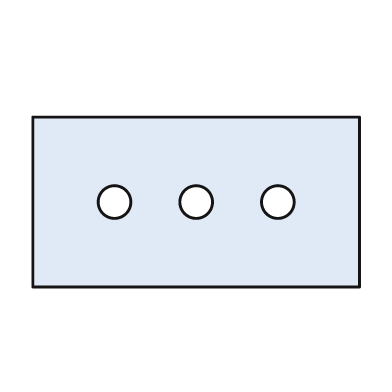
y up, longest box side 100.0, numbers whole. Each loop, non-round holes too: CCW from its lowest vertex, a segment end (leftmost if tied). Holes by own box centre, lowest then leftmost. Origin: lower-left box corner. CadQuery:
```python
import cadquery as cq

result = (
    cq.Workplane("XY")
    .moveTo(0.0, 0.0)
    .lineTo(100.0, 0.0)
    .lineTo(100.0, 52.0)
    .lineTo(0.0, 52.0)
    .close()
    .moveTo(25.0, 26.0)
    .circle(5.0)
    .moveTo(50.0, 26.0)
    .circle(5.0)
    .moveTo(75.0, 26.0)
    .circle(5.0)
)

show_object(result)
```